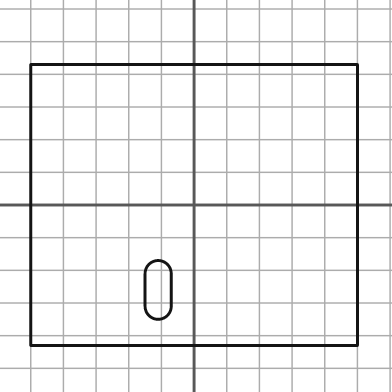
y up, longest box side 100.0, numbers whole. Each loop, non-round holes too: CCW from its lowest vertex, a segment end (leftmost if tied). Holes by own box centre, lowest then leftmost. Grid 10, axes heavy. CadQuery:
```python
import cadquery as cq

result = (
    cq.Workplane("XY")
    .moveTo(-50.0, -43.0)
    .lineTo(50.0, -43.0)
    .lineTo(50.0, 43.0)
    .lineTo(-50.0, 43.0)
    .close()
    .moveTo(-15.0, -31.0)
    .threePointArc((-11.0, -35.0), (-7.0, -31.0))
    .lineTo(-7.0, -21.0)
    .threePointArc((-11.0, -17.0), (-15.0, -21.0))
    .close()
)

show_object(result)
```